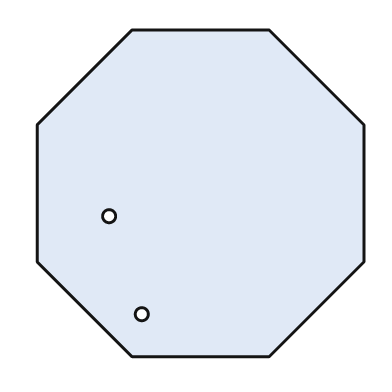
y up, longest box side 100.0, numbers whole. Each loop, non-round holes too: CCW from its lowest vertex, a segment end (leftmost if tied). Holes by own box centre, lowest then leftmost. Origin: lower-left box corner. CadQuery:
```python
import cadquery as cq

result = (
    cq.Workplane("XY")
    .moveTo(29.0, 0.0)
    .lineTo(71.0, 0.0)
    .lineTo(100.0, 29.0)
    .lineTo(100.0, 71.0)
    .lineTo(71.0, 100.0)
    .lineTo(29.0, 100.0)
    .lineTo(0.0, 71.0)
    .lineTo(0.0, 29.0)
    .close()
    .moveTo(32.0, 13.0)
    .circle(2.0)
    .moveTo(22.0, 43.0)
    .circle(2.0)
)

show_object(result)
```